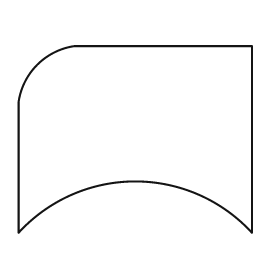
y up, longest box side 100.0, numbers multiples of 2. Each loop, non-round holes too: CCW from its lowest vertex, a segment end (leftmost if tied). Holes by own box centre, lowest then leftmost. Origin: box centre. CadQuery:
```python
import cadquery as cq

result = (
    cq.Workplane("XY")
    .moveTo(-50.0, -40.0)
    .threePointArc((0.0, -18.0), (50.0, -40.0))
    .lineTo(50.0, 40.0)
    .lineTo(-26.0, 40.0)
    .threePointArc((-42.0, 32.0), (-50.0, 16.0))
    .close()
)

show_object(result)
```